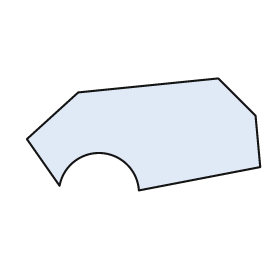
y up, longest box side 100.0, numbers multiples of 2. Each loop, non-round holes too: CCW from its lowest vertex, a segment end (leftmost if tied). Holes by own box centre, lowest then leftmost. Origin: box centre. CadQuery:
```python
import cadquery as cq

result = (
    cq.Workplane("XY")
    .moveTo(-2.0, -24.0)
    .lineTo(50.0, -14.0)
    .lineTo(48.0, 8.0)
    .lineTo(32.0, 24.0)
    .lineTo(-28.0, 18.0)
    .lineTo(-50.0, -2.0)
    .lineTo(-36.0, -22.0)
    .threePointArc((-18.0, -8.0), (-2.0, -24.0))
    .close()
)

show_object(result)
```